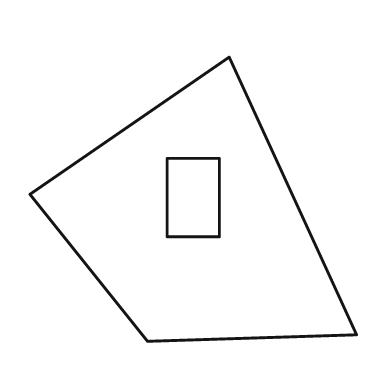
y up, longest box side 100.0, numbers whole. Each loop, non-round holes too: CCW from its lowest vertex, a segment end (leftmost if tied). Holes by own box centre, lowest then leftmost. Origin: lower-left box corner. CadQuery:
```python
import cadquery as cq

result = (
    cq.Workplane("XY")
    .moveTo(36.0, 0.0)
    .lineTo(100.0, 2.0)
    .lineTo(61.0, 87.0)
    .lineTo(0.0, 45.0)
    .close()
    .moveTo(42.0, 32.0)
    .lineTo(58.0, 32.0)
    .lineTo(58.0, 56.0)
    .lineTo(42.0, 56.0)
    .close()
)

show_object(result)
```